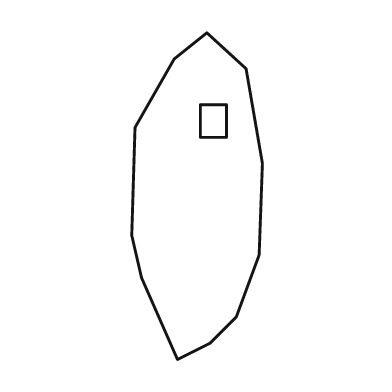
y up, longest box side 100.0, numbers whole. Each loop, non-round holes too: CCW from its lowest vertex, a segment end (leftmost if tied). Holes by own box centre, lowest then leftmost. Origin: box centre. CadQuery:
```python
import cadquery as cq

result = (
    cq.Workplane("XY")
    .moveTo(-6.0, -50.0)
    .lineTo(4.0, -45.0)
    .lineTo(12.0, -37.0)
    .lineTo(19.0, -18.0)
    .lineTo(20.0, 10.0)
    .lineTo(15.0, 39.0)
    .lineTo(3.0, 50.0)
    .lineTo(-7.0, 42.0)
    .lineTo(-19.0, 21.0)
    .lineTo(-20.0, -12.0)
    .lineTo(-17.0, -25.0)
    .close()
    .moveTo(1.0, 18.0)
    .lineTo(9.0, 18.0)
    .lineTo(9.0, 28.0)
    .lineTo(1.0, 28.0)
    .close()
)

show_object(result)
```